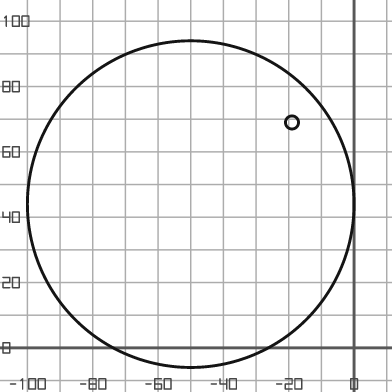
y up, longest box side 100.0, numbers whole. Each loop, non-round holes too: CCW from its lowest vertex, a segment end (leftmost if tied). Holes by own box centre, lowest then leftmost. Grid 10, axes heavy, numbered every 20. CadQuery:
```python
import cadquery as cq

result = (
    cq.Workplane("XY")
    .moveTo(-50.0, 44.0)
    .circle(50.0)
    .moveTo(-19.0, 69.0)
    .circle(2.0)
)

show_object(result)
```